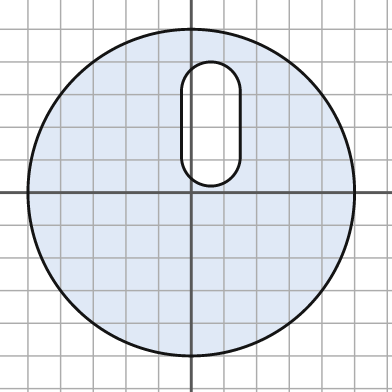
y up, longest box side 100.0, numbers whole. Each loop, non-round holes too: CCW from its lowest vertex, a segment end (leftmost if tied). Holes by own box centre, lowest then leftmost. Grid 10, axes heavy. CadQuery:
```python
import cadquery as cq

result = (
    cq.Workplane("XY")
    .moveTo(0.0, 0.0)
    .circle(50.0)
    .moveTo(-3.0, 11.0)
    .threePointArc((6.0, 2.0), (15.0, 11.0))
    .lineTo(15.0, 31.0)
    .threePointArc((6.0, 40.0), (-3.0, 31.0))
    .close()
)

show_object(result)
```